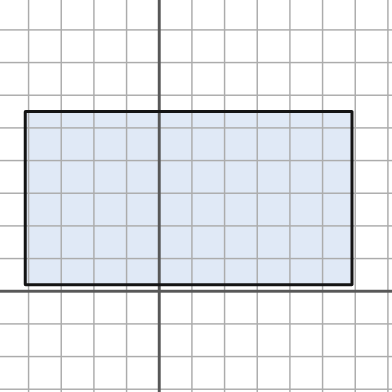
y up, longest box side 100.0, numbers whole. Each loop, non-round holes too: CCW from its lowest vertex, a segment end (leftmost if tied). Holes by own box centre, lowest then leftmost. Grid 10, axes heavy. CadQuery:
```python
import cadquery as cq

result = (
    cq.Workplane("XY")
    .moveTo(-41.0, 2.0)
    .lineTo(59.0, 2.0)
    .lineTo(59.0, 55.0)
    .lineTo(-41.0, 55.0)
    .close()
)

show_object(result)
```